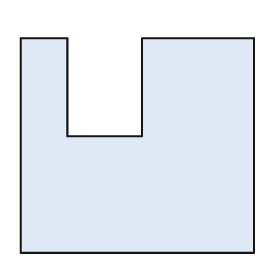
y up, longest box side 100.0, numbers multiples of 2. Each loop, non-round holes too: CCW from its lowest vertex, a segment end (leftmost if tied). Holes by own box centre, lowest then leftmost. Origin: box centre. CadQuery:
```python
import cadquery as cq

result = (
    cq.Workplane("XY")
    .moveTo(-50.0, -46.0)
    .lineTo(50.0, -46.0)
    .lineTo(50.0, 46.0)
    .lineTo(2.0, 46.0)
    .lineTo(2.0, 4.0)
    .lineTo(-30.0, 4.0)
    .lineTo(-30.0, 46.0)
    .lineTo(-50.0, 46.0)
    .close()
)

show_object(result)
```